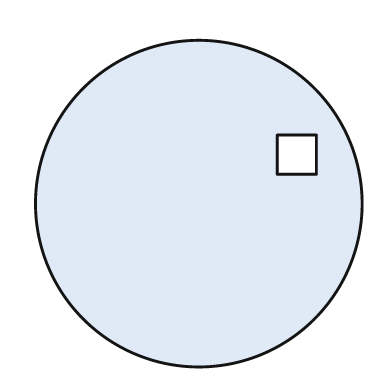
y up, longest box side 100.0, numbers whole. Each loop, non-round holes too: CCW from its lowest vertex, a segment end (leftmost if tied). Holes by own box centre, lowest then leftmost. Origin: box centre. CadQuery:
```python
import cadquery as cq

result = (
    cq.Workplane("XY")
    .moveTo(0.0, 0.0)
    .circle(50.0)
    .moveTo(24.0, 9.0)
    .lineTo(36.0, 9.0)
    .lineTo(36.0, 21.0)
    .lineTo(24.0, 21.0)
    .close()
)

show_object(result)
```